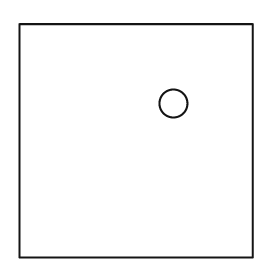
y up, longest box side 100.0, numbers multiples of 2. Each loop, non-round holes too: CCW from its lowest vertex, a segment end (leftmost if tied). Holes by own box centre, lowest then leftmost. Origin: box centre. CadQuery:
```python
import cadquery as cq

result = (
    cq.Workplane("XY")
    .moveTo(-50.0, -50.0)
    .lineTo(50.0, -50.0)
    .lineTo(50.0, 50.0)
    .lineTo(-50.0, 50.0)
    .close()
    .moveTo(16.0, 16.0)
    .circle(6.0)
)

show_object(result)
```